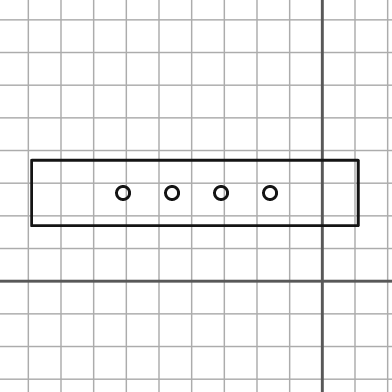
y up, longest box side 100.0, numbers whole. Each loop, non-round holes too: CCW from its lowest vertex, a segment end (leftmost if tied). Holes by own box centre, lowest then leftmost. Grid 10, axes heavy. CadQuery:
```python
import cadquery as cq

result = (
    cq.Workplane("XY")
    .moveTo(-89.0, 17.0)
    .lineTo(11.0, 17.0)
    .lineTo(11.0, 37.0)
    .lineTo(-89.0, 37.0)
    .close()
    .moveTo(-61.0, 27.0)
    .circle(2.0)
    .moveTo(-46.0, 27.0)
    .circle(2.0)
    .moveTo(-31.0, 27.0)
    .circle(2.0)
    .moveTo(-16.0, 27.0)
    .circle(2.0)
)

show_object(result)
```